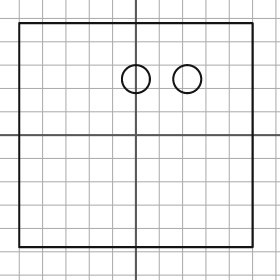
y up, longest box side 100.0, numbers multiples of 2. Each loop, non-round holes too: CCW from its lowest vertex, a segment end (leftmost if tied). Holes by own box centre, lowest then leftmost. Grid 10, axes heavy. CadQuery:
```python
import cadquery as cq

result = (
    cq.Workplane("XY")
    .moveTo(-50.0, -48.0)
    .lineTo(50.0, -48.0)
    .lineTo(50.0, 48.0)
    .lineTo(-50.0, 48.0)
    .close()
    .moveTo(0.0, 24.0)
    .circle(6.0)
    .moveTo(22.0, 24.0)
    .circle(6.0)
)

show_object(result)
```